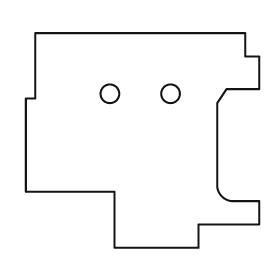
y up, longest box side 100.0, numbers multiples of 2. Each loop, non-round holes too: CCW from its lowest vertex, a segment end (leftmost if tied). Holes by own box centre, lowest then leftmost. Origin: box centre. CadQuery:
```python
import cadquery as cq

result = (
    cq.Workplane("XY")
    .moveTo(-12.0, -46.0)
    .lineTo(24.0, -46.0)
    .lineTo(24.0, -36.0)
    .lineTo(50.0, -36.0)
    .lineTo(50.0, -26.0)
    .lineTo(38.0, -26.0)
    .threePointArc((34.0, -24.0), (32.0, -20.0))
    .lineTo(32.0, 16.0)
    .lineTo(36.0, 22.0)
    .lineTo(50.0, 22.0)
    .lineTo(50.0, 36.0)
    .lineTo(44.0, 36.0)
    .lineTo(44.0, 46.0)
    .lineTo(-46.0, 46.0)
    .lineTo(-46.0, 18.0)
    .lineTo(-50.0, 18.0)
    .lineTo(-50.0, -22.0)
    .lineTo(-12.0, -22.0)
    .close()
    .moveTo(-14.0, 20.0)
    .circle(4.0)
    .moveTo(12.0, 20.0)
    .circle(4.0)
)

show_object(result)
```